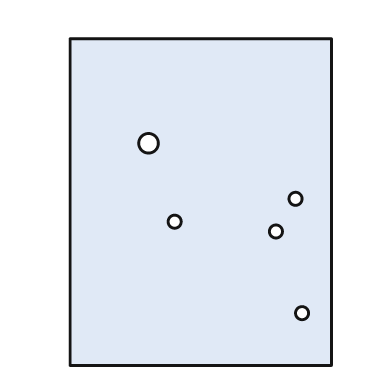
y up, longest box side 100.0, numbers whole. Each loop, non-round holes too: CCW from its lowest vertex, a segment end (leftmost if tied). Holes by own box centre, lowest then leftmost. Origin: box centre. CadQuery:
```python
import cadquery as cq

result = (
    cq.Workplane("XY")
    .moveTo(-40.0, -50.0)
    .lineTo(40.0, -50.0)
    .lineTo(40.0, 50.0)
    .lineTo(-40.0, 50.0)
    .close()
    .moveTo(31.0, -34.0)
    .circle(2.0)
    .moveTo(23.0, -9.0)
    .circle(2.0)
    .moveTo(-8.0, -6.0)
    .circle(2.0)
    .moveTo(29.0, 1.0)
    .circle(2.0)
    .moveTo(-16.0, 18.0)
    .circle(3.0)
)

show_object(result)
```